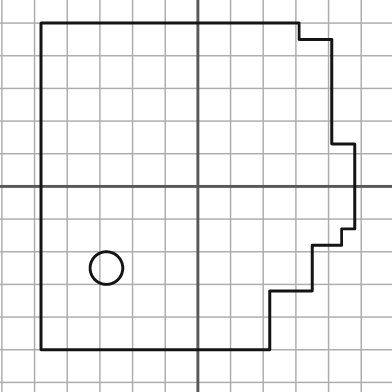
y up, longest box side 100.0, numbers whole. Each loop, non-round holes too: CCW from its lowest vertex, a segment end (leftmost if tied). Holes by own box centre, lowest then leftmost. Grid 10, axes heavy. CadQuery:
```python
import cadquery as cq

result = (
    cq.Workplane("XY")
    .moveTo(-48.0, -50.0)
    .lineTo(22.0, -50.0)
    .lineTo(22.0, -32.0)
    .lineTo(35.0, -32.0)
    .lineTo(35.0, -18.0)
    .lineTo(44.0, -18.0)
    .lineTo(44.0, -13.0)
    .lineTo(48.0, -13.0)
    .lineTo(48.0, 13.0)
    .lineTo(41.0, 13.0)
    .lineTo(41.0, 45.0)
    .lineTo(31.0, 45.0)
    .lineTo(31.0, 50.0)
    .lineTo(-48.0, 50.0)
    .close()
    .moveTo(-28.0, -25.0)
    .circle(5.0)
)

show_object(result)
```